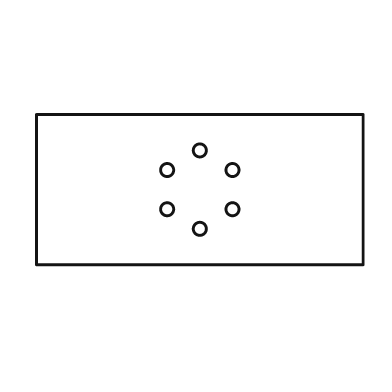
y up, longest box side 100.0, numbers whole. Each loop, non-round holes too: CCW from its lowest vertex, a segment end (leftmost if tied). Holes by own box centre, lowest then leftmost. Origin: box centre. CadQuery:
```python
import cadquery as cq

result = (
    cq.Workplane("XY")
    .moveTo(-50.0, -23.0)
    .lineTo(50.0, -23.0)
    .lineTo(50.0, 23.0)
    .lineTo(-50.0, 23.0)
    .close()
    .moveTo(0.0, -12.0)
    .circle(2.0)
    .moveTo(-10.0, -6.0)
    .circle(2.0)
    .moveTo(10.0, -6.0)
    .circle(2.0)
    .moveTo(-10.0, 6.0)
    .circle(2.0)
    .moveTo(10.0, 6.0)
    .circle(2.0)
    .moveTo(0.0, 12.0)
    .circle(2.0)
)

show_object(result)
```